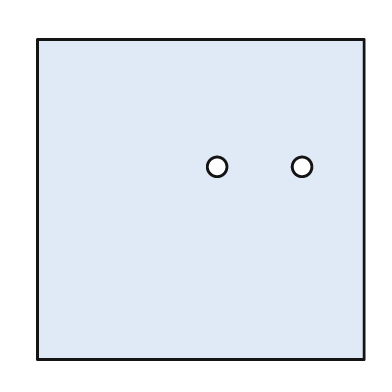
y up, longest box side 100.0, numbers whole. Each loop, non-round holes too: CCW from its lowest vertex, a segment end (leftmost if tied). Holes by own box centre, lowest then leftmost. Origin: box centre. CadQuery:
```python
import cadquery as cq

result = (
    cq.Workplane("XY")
    .moveTo(-50.0, -49.0)
    .lineTo(50.0, -49.0)
    .lineTo(50.0, 49.0)
    .lineTo(-50.0, 49.0)
    .close()
    .moveTo(5.0, 10.0)
    .circle(3.0)
    .moveTo(31.0, 10.0)
    .circle(3.0)
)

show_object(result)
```